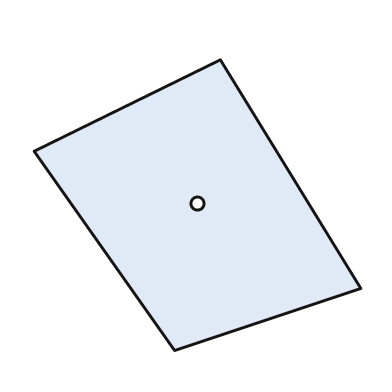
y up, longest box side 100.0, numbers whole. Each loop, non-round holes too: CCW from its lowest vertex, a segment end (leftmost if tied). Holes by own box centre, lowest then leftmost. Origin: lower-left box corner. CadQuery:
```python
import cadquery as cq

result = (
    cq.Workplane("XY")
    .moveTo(43.0, 0.0)
    .lineTo(100.0, 19.0)
    .lineTo(57.0, 89.0)
    .lineTo(0.0, 61.0)
    .close()
    .moveTo(50.0, 45.0)
    .circle(2.0)
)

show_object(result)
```